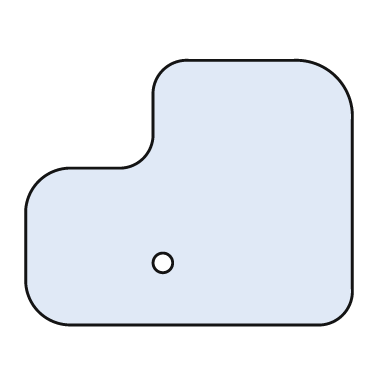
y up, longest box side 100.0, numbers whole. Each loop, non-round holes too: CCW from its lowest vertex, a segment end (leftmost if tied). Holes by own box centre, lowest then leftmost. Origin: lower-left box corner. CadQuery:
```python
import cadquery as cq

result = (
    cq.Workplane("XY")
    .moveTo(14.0, 0.0)
    .lineTo(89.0, 0.0)
    .threePointArc((97.0, 3.0), (100.0, 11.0))
    .lineTo(100.0, 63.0)
    .threePointArc((95.0, 76.0), (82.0, 81.0))
    .lineTo(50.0, 81.0)
    .threePointArc((42.0, 78.0), (39.0, 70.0))
    .lineTo(39.0, 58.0)
    .threePointArc((36.0, 51.0), (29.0, 48.0))
    .lineTo(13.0, 48.0)
    .threePointArc((4.0, 44.0), (0.0, 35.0))
    .lineTo(0.0, 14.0)
    .threePointArc((4.0, 4.0), (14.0, 0.0))
    .close()
    .moveTo(42.0, 19.0)
    .circle(3.0)
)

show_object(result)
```